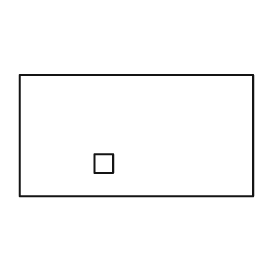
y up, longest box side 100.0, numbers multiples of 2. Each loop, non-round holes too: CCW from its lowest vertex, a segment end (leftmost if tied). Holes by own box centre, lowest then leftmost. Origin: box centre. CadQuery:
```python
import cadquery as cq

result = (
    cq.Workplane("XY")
    .moveTo(-50.0, -26.0)
    .lineTo(50.0, -26.0)
    .lineTo(50.0, 26.0)
    .lineTo(-50.0, 26.0)
    .close()
    .moveTo(-18.0, -16.0)
    .lineTo(-10.0, -16.0)
    .lineTo(-10.0, -8.0)
    .lineTo(-18.0, -8.0)
    .close()
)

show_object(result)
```